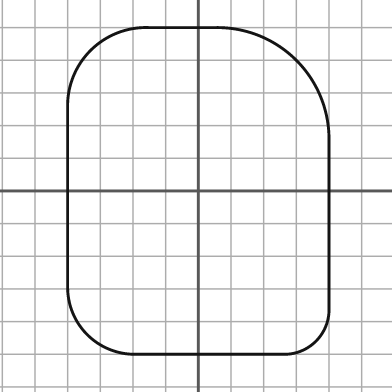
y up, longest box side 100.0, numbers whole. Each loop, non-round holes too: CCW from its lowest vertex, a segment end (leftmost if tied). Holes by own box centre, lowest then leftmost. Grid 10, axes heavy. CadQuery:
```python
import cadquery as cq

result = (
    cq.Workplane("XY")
    .moveTo(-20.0, -50.0)
    .lineTo(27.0, -50.0)
    .threePointArc((36.0, -46.0), (40.0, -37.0))
    .lineTo(40.0, 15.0)
    .threePointArc((30.0, 40.0), (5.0, 50.0))
    .lineTo(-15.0, 50.0)
    .threePointArc((-33.0, 43.0), (-40.0, 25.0))
    .lineTo(-40.0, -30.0)
    .threePointArc((-34.0, -44.0), (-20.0, -50.0))
    .close()
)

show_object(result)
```